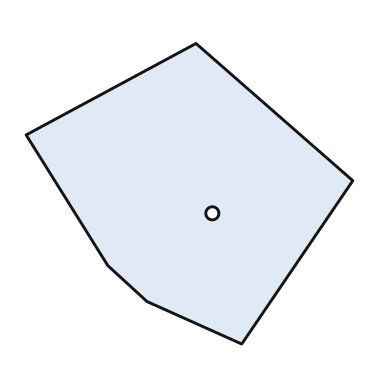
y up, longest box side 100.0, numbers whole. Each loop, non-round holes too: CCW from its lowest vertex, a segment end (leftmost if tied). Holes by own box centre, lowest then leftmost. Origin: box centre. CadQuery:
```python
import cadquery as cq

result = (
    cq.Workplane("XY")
    .moveTo(16.0, -46.0)
    .lineTo(50.0, 4.0)
    .lineTo(2.0, 46.0)
    .lineTo(-50.0, 18.0)
    .lineTo(-25.0, -22.0)
    .lineTo(-13.0, -33.0)
    .close()
    .moveTo(7.0, -6.0)
    .circle(2.0)
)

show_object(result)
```